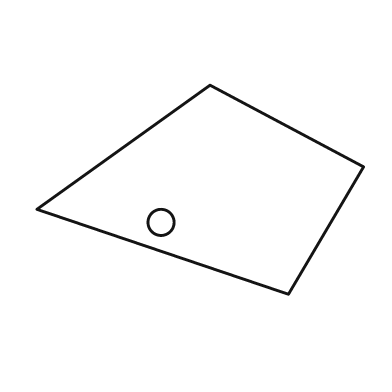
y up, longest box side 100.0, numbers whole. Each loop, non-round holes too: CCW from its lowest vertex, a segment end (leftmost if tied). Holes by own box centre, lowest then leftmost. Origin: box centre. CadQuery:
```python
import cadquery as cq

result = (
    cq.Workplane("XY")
    .moveTo(27.0, -32.0)
    .lineTo(50.0, 7.0)
    .lineTo(3.0, 32.0)
    .lineTo(-50.0, -6.0)
    .close()
    .moveTo(-12.0, -10.0)
    .circle(4.0)
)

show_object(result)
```